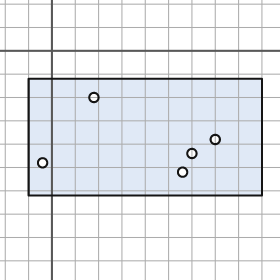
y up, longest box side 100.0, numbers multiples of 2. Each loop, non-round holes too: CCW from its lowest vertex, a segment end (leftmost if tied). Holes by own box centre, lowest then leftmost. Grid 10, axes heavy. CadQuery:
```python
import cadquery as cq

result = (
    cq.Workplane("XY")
    .moveTo(-10.0, -62.0)
    .lineTo(90.0, -62.0)
    .lineTo(90.0, -12.0)
    .lineTo(-10.0, -12.0)
    .close()
    .moveTo(56.0, -52.0)
    .circle(2.0)
    .moveTo(-4.0, -48.0)
    .circle(2.0)
    .moveTo(60.0, -44.0)
    .circle(2.0)
    .moveTo(70.0, -38.0)
    .circle(2.0)
    .moveTo(18.0, -20.0)
    .circle(2.0)
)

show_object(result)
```